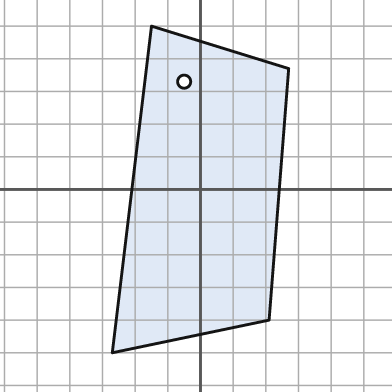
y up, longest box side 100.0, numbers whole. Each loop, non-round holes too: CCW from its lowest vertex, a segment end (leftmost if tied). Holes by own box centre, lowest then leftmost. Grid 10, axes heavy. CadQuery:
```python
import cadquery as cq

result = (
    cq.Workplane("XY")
    .moveTo(-27.0, -50.0)
    .lineTo(21.0, -40.0)
    .lineTo(27.0, 37.0)
    .lineTo(-15.0, 50.0)
    .close()
    .moveTo(-5.0, 33.0)
    .circle(2.0)
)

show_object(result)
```